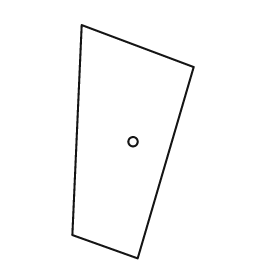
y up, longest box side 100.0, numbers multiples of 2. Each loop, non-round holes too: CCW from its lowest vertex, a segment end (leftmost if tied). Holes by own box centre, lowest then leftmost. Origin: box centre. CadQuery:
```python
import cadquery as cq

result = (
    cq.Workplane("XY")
    .moveTo(2.0, -50.0)
    .lineTo(26.0, 32.0)
    .lineTo(-22.0, 50.0)
    .lineTo(-26.0, -40.0)
    .close()
    .moveTo(0.0, 0.0)
    .circle(2.0)
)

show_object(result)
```